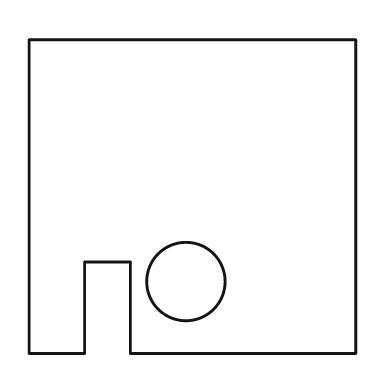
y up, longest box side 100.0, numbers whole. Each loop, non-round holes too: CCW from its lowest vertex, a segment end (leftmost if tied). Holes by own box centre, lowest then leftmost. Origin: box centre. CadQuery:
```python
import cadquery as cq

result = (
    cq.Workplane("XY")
    .moveTo(-50.0, -48.0)
    .lineTo(-33.0, -48.0)
    .lineTo(-33.0, -20.0)
    .lineTo(-19.0, -20.0)
    .lineTo(-19.0, -48.0)
    .lineTo(50.0, -48.0)
    .lineTo(50.0, 48.0)
    .lineTo(-50.0, 48.0)
    .close()
    .moveTo(-2.0, -26.0)
    .circle(12.0)
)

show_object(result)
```